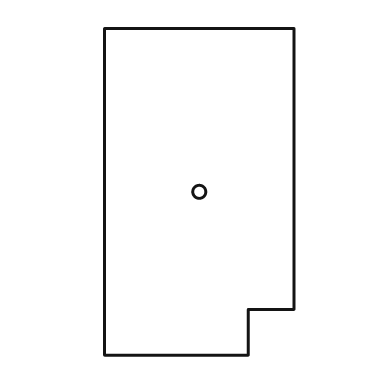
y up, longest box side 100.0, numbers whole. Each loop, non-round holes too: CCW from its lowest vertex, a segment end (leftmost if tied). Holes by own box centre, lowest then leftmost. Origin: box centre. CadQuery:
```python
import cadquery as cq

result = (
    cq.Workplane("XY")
    .moveTo(-29.0, -50.0)
    .lineTo(15.0, -50.0)
    .lineTo(15.0, -36.0)
    .lineTo(29.0, -36.0)
    .lineTo(29.0, 50.0)
    .lineTo(-29.0, 50.0)
    .close()
    .moveTo(0.0, 0.0)
    .circle(2.0)
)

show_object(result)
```